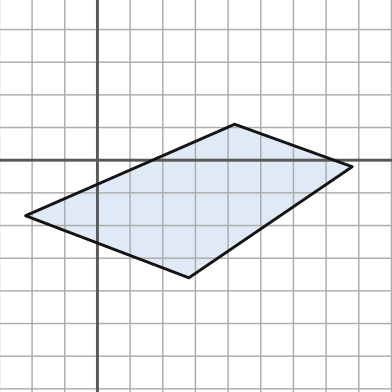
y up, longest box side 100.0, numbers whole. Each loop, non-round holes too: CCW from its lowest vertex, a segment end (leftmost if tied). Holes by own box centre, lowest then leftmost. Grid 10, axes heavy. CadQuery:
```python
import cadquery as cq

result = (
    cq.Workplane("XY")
    .moveTo(28.0, -36.0)
    .lineTo(78.0, -2.0)
    .lineTo(42.0, 11.0)
    .lineTo(-22.0, -17.0)
    .close()
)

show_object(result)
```